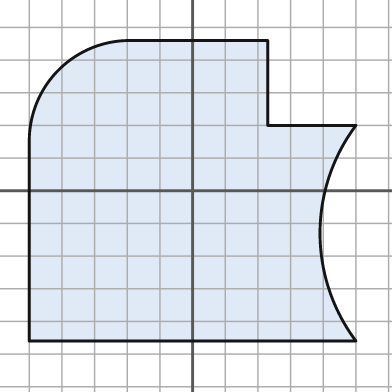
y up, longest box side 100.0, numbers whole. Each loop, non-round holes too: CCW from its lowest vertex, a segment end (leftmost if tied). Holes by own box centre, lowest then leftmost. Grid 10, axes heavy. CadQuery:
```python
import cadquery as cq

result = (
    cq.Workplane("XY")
    .moveTo(-50.0, -46.0)
    .lineTo(50.0, -46.0)
    .threePointArc((39.0, -13.0), (50.0, 20.0))
    .lineTo(23.0, 20.0)
    .lineTo(23.0, 46.0)
    .lineTo(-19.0, 46.0)
    .threePointArc((-41.0, 37.0), (-50.0, 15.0))
    .close()
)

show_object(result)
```